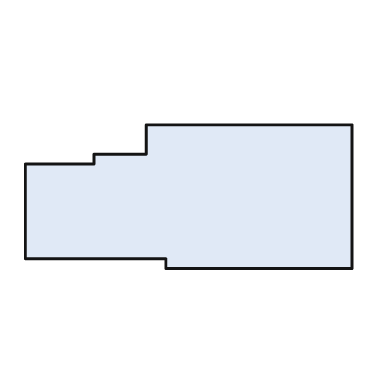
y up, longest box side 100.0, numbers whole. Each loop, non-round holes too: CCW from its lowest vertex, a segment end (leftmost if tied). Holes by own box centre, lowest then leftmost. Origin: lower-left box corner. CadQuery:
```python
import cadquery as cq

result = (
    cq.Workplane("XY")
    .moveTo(43.0, 0.0)
    .lineTo(100.0, 0.0)
    .lineTo(100.0, 44.0)
    .lineTo(37.0, 44.0)
    .lineTo(37.0, 35.0)
    .lineTo(21.0, 35.0)
    .lineTo(21.0, 32.0)
    .lineTo(0.0, 32.0)
    .lineTo(0.0, 3.0)
    .lineTo(43.0, 3.0)
    .close()
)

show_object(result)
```